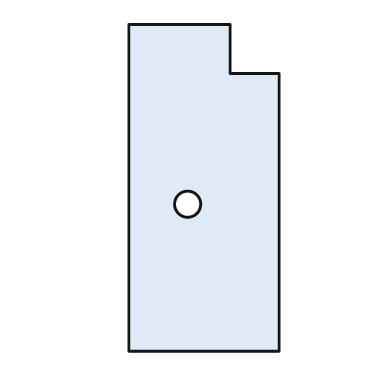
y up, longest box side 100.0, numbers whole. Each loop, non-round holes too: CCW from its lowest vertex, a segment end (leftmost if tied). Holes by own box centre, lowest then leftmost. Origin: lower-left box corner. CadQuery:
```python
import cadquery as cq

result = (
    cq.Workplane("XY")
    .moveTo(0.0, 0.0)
    .lineTo(46.0, 0.0)
    .lineTo(46.0, 85.0)
    .lineTo(31.0, 85.0)
    .lineTo(31.0, 100.0)
    .lineTo(0.0, 100.0)
    .close()
    .moveTo(18.0, 45.0)
    .circle(4.0)
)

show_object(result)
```